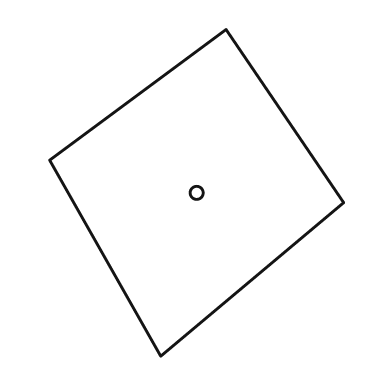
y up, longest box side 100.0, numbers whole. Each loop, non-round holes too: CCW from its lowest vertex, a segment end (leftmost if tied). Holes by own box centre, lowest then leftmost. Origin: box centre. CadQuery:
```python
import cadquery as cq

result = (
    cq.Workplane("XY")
    .moveTo(-11.0, -50.0)
    .lineTo(45.0, -3.0)
    .lineTo(9.0, 50.0)
    .lineTo(-45.0, 10.0)
    .close()
    .moveTo(0.0, 0.0)
    .circle(2.0)
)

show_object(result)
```